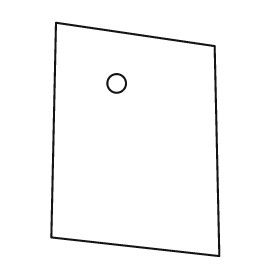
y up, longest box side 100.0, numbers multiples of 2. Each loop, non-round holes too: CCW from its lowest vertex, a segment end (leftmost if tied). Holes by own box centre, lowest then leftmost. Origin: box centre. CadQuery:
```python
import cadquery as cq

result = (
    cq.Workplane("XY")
    .moveTo(36.0, -50.0)
    .lineTo(34.0, 40.0)
    .lineTo(-34.0, 50.0)
    .lineTo(-36.0, -42.0)
    .close()
    .moveTo(-8.0, 24.0)
    .circle(4.0)
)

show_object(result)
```